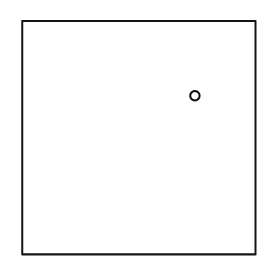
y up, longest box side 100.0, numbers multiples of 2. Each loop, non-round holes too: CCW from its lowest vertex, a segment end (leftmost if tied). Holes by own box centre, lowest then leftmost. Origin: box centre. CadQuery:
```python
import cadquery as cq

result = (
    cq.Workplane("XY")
    .moveTo(-50.0, -50.0)
    .lineTo(50.0, -50.0)
    .lineTo(50.0, 50.0)
    .lineTo(-50.0, 50.0)
    .close()
    .moveTo(24.0, 18.0)
    .circle(2.0)
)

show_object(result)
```